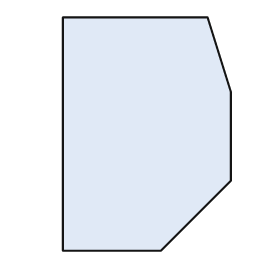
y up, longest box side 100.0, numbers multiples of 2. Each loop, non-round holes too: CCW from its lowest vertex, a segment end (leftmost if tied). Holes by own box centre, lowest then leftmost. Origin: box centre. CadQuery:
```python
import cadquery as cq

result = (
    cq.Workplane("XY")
    .moveTo(-36.0, -50.0)
    .lineTo(6.0, -50.0)
    .lineTo(36.0, -20.0)
    .lineTo(36.0, 18.0)
    .lineTo(26.0, 50.0)
    .lineTo(-36.0, 50.0)
    .close()
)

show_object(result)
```